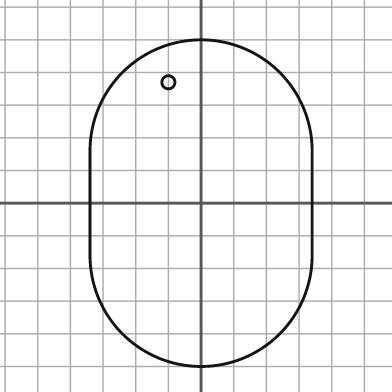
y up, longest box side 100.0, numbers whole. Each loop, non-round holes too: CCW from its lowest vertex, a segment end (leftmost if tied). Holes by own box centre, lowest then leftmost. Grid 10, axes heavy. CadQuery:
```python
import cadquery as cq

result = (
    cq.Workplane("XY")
    .moveTo(-34.0, -16.0)
    .threePointArc((0.0, -50.0), (34.0, -16.0))
    .lineTo(34.0, 16.0)
    .threePointArc((0.0, 50.0), (-34.0, 16.0))
    .close()
    .moveTo(-10.0, 37.0)
    .circle(2.0)
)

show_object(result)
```